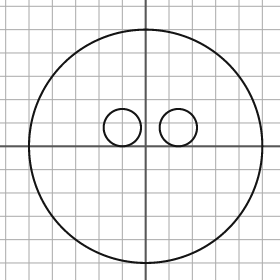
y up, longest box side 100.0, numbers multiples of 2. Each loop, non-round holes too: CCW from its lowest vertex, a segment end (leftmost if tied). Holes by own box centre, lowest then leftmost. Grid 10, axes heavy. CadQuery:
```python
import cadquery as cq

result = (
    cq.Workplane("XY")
    .moveTo(0.0, 0.0)
    .circle(50.0)
    .moveTo(-10.0, 8.0)
    .circle(8.0)
    .moveTo(14.0, 8.0)
    .circle(8.0)
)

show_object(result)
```